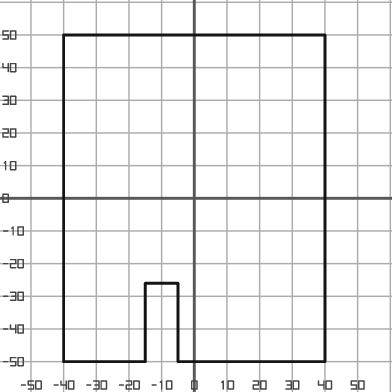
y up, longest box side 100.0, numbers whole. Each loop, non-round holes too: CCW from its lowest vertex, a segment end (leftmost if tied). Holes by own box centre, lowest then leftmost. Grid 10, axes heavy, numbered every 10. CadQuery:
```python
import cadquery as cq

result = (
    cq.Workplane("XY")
    .moveTo(-40.0, -50.0)
    .lineTo(-15.0, -50.0)
    .lineTo(-15.0, -26.0)
    .lineTo(-5.0, -26.0)
    .lineTo(-5.0, -50.0)
    .lineTo(40.0, -50.0)
    .lineTo(40.0, 50.0)
    .lineTo(-40.0, 50.0)
    .close()
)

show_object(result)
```